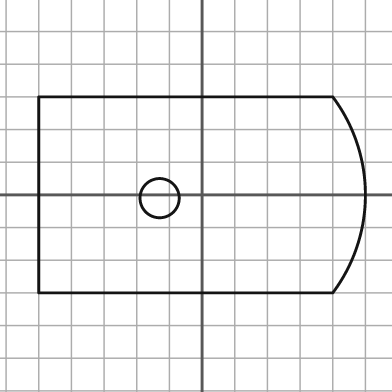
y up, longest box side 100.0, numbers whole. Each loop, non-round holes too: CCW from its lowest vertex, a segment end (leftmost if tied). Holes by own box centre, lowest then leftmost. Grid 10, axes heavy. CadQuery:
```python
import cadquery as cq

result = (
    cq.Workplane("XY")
    .moveTo(-50.0, -30.0)
    .lineTo(40.0, -30.0)
    .threePointArc((50.0, 0.0), (40.0, 30.0))
    .lineTo(-50.0, 30.0)
    .close()
    .moveTo(-13.0, -1.0)
    .circle(6.0)
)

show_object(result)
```